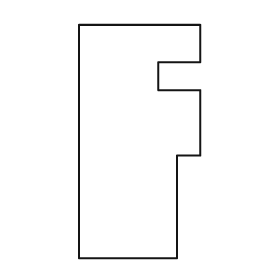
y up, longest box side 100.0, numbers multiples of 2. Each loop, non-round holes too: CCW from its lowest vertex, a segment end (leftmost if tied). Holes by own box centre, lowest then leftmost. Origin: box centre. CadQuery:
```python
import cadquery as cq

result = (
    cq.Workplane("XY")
    .moveTo(-26.0, -50.0)
    .lineTo(16.0, -50.0)
    .lineTo(16.0, -6.0)
    .lineTo(26.0, -6.0)
    .lineTo(26.0, 22.0)
    .lineTo(8.0, 22.0)
    .lineTo(8.0, 34.0)
    .lineTo(26.0, 34.0)
    .lineTo(26.0, 50.0)
    .lineTo(-26.0, 50.0)
    .close()
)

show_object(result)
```